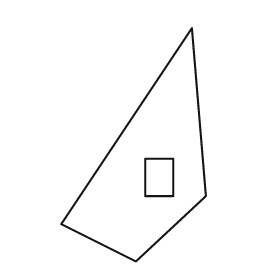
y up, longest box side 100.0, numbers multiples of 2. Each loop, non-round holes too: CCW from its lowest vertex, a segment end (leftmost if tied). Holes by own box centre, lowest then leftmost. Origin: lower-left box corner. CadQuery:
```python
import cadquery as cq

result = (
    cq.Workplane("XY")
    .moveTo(32.0, 0.0)
    .lineTo(62.0, 28.0)
    .lineTo(56.0, 100.0)
    .lineTo(0.0, 16.0)
    .close()
    .moveTo(36.0, 28.0)
    .lineTo(48.0, 28.0)
    .lineTo(48.0, 44.0)
    .lineTo(36.0, 44.0)
    .close()
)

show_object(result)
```